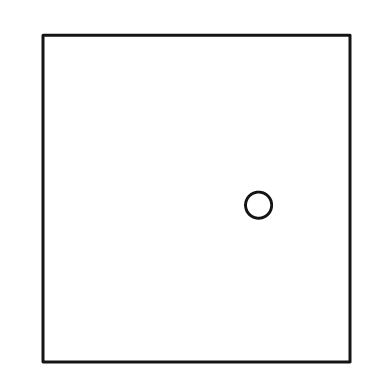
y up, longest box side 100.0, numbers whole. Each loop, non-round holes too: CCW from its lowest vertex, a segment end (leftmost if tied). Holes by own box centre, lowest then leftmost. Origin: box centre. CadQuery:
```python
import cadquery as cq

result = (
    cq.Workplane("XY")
    .moveTo(-47.0, -50.0)
    .lineTo(47.0, -50.0)
    .lineTo(47.0, 50.0)
    .lineTo(-47.0, 50.0)
    .close()
    .moveTo(19.0, -2.0)
    .circle(4.0)
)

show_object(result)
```